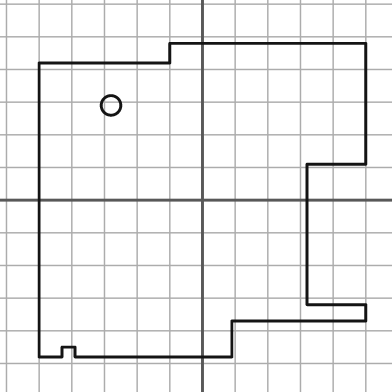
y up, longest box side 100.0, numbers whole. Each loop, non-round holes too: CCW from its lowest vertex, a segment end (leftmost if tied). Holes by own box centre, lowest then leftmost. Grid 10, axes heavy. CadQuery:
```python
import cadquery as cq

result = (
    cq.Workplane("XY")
    .moveTo(-50.0, -48.0)
    .lineTo(-43.0, -48.0)
    .lineTo(-43.0, -45.0)
    .lineTo(-39.0, -45.0)
    .lineTo(-39.0, -48.0)
    .lineTo(9.0, -48.0)
    .lineTo(9.0, -37.0)
    .lineTo(50.0, -37.0)
    .lineTo(50.0, -32.0)
    .lineTo(32.0, -32.0)
    .lineTo(32.0, 11.0)
    .lineTo(50.0, 11.0)
    .lineTo(50.0, 48.0)
    .lineTo(-10.0, 48.0)
    .lineTo(-10.0, 42.0)
    .lineTo(-50.0, 42.0)
    .close()
    .moveTo(-28.0, 29.0)
    .circle(3.0)
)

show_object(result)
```